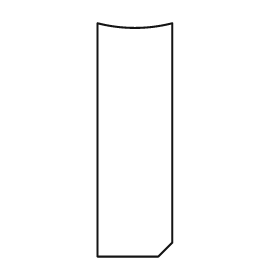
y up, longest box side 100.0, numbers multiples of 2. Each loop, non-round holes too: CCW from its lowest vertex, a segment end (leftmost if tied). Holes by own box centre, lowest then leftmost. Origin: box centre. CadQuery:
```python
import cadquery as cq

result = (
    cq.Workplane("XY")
    .moveTo(-16.0, -50.0)
    .lineTo(10.0, -50.0)
    .lineTo(16.0, -44.0)
    .lineTo(16.0, 50.0)
    .threePointArc((0.0, 48.0), (-16.0, 50.0))
    .close()
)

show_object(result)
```